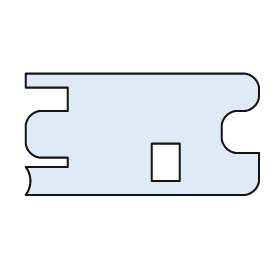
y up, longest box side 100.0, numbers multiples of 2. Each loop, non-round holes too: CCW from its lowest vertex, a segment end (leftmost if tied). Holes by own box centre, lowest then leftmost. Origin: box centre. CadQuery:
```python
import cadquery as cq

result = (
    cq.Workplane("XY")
    .moveTo(-50.0, -26.0)
    .lineTo(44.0, -26.0)
    .threePointArc((48.0, -24.0), (50.0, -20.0))
    .lineTo(50.0, -8.0)
    .lineTo(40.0, -8.0)
    .threePointArc((36.0, -6.0), (34.0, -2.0))
    .lineTo(34.0, 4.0)
    .threePointArc((36.0, 8.0), (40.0, 10.0))
    .lineTo(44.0, 10.0)
    .threePointArc((48.0, 12.0), (50.0, 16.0))
    .lineTo(50.0, 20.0)
    .threePointArc((48.0, 24.0), (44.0, 26.0))
    .lineTo(-50.0, 26.0)
    .lineTo(-50.0, 20.0)
    .lineTo(-32.0, 20.0)
    .lineTo(-32.0, 10.0)
    .lineTo(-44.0, 10.0)
    .threePointArc((-48.0, 8.0), (-50.0, 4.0))
    .lineTo(-50.0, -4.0)
    .threePointArc((-48.0, -8.0), (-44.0, -10.0))
    .lineTo(-32.0, -10.0)
    .lineTo(-32.0, -14.0)
    .lineTo(-50.0, -14.0)
    .threePointArc((-48.0, -20.0), (-50.0, -26.0))
    .close()
    .moveTo(4.0, -20.0)
    .lineTo(16.0, -20.0)
    .lineTo(16.0, -4.0)
    .lineTo(4.0, -4.0)
    .close()
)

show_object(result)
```